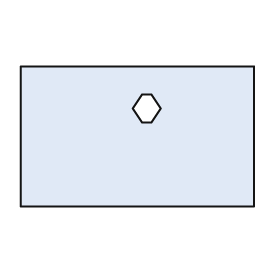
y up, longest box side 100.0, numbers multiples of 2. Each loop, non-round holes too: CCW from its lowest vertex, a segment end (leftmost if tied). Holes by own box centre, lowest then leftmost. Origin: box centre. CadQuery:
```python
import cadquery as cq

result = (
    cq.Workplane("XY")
    .moveTo(-50.0, -30.0)
    .lineTo(50.0, -30.0)
    .lineTo(50.0, 30.0)
    .lineTo(-50.0, 30.0)
    .close()
    .moveTo(2.0, 6.0)
    .lineTo(6.0, 6.0)
    .lineTo(10.0, 12.0)
    .lineTo(6.0, 18.0)
    .lineTo(2.0, 18.0)
    .lineTo(-2.0, 12.0)
    .close()
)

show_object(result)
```